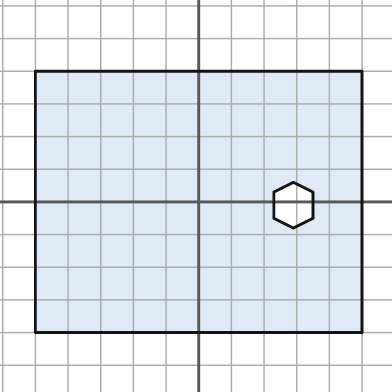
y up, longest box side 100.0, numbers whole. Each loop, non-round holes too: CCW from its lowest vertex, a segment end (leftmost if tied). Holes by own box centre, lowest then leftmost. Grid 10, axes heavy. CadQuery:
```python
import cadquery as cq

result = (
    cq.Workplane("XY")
    .moveTo(-50.0, -40.0)
    .lineTo(50.0, -40.0)
    .lineTo(50.0, 40.0)
    .lineTo(-50.0, 40.0)
    .close()
    .moveTo(29.0, -8.0)
    .lineTo(35.0, -5.0)
    .lineTo(35.0, 3.0)
    .lineTo(29.0, 6.0)
    .lineTo(23.0, 3.0)
    .lineTo(23.0, -5.0)
    .close()
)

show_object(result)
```